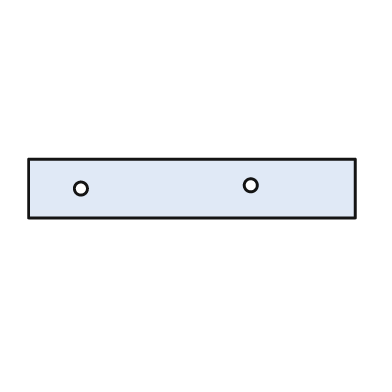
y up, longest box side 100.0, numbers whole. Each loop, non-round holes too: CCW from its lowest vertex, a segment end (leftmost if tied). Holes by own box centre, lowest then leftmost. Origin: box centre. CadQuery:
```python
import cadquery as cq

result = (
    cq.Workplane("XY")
    .moveTo(-50.0, -9.0)
    .lineTo(50.0, -9.0)
    .lineTo(50.0, 9.0)
    .lineTo(-50.0, 9.0)
    .close()
    .moveTo(-34.0, 0.0)
    .circle(2.0)
    .moveTo(18.0, 1.0)
    .circle(2.0)
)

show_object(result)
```